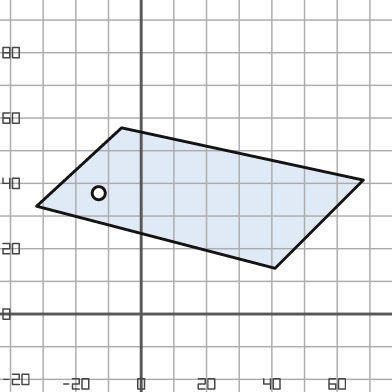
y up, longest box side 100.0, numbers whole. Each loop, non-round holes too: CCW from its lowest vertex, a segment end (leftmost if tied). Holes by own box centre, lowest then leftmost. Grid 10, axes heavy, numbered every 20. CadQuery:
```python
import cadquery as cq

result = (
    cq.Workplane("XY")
    .moveTo(41.0, 14.0)
    .lineTo(68.0, 41.0)
    .lineTo(-6.0, 57.0)
    .lineTo(-32.0, 33.0)
    .close()
    .moveTo(-13.0, 37.0)
    .circle(2.0)
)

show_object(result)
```